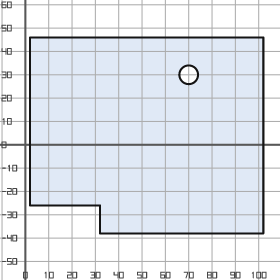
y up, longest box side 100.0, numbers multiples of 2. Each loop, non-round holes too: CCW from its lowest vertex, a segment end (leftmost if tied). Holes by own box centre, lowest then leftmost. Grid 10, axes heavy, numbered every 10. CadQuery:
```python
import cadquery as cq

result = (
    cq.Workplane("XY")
    .moveTo(32.0, -38.0)
    .lineTo(102.0, -38.0)
    .lineTo(102.0, 46.0)
    .lineTo(2.0, 46.0)
    .lineTo(2.0, -26.0)
    .lineTo(32.0, -26.0)
    .close()
    .moveTo(70.0, 30.0)
    .circle(4.0)
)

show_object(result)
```